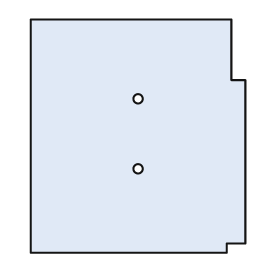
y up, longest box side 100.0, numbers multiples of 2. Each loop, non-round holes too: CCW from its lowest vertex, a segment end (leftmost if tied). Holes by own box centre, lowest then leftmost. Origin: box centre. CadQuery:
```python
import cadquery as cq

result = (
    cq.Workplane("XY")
    .moveTo(-46.0, -50.0)
    .lineTo(38.0, -50.0)
    .lineTo(38.0, -46.0)
    .lineTo(46.0, -46.0)
    .lineTo(46.0, 24.0)
    .lineTo(40.0, 24.0)
    .lineTo(40.0, 50.0)
    .lineTo(-46.0, 50.0)
    .close()
    .moveTo(0.0, -14.0)
    .circle(2.0)
    .moveTo(0.0, 16.0)
    .circle(2.0)
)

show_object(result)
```